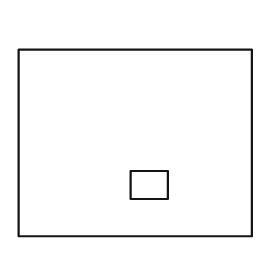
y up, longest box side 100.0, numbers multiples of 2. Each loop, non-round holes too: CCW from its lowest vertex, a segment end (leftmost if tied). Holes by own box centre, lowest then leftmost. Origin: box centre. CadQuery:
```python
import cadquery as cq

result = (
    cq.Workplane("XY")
    .moveTo(-50.0, -40.0)
    .lineTo(50.0, -40.0)
    .lineTo(50.0, 40.0)
    .lineTo(-50.0, 40.0)
    .close()
    .moveTo(-2.0, -24.0)
    .lineTo(14.0, -24.0)
    .lineTo(14.0, -12.0)
    .lineTo(-2.0, -12.0)
    .close()
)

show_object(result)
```